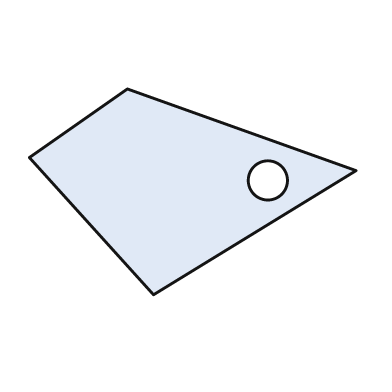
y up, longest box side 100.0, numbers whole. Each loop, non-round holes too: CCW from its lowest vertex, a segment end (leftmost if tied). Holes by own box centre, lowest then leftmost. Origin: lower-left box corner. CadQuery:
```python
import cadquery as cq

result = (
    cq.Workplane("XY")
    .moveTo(38.0, 0.0)
    .lineTo(100.0, 38.0)
    .lineTo(30.0, 63.0)
    .lineTo(0.0, 42.0)
    .close()
    .moveTo(73.0, 35.0)
    .circle(6.0)
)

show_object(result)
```